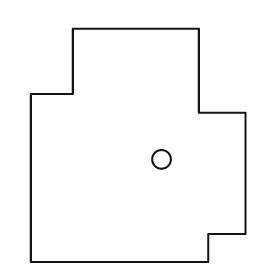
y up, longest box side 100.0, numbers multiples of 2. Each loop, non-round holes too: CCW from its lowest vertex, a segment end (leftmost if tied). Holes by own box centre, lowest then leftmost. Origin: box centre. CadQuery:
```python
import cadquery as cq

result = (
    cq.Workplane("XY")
    .moveTo(-46.0, -50.0)
    .lineTo(30.0, -50.0)
    .lineTo(30.0, -38.0)
    .lineTo(46.0, -38.0)
    .lineTo(46.0, 14.0)
    .lineTo(26.0, 14.0)
    .lineTo(26.0, 50.0)
    .lineTo(-28.0, 50.0)
    .lineTo(-28.0, 22.0)
    .lineTo(-46.0, 22.0)
    .close()
    .moveTo(10.0, -6.0)
    .circle(4.0)
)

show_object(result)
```